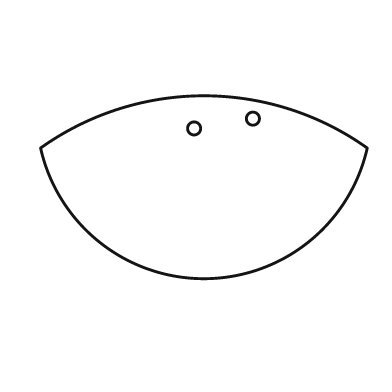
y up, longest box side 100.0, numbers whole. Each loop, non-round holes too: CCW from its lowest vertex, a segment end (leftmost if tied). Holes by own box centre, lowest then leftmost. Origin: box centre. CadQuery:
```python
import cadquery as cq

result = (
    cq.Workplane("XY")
    .moveTo(-50.0, 12.0)
    .threePointArc((0.0, -28.0), (50.0, 12.0))
    .threePointArc((0.0, 28.0), (-50.0, 12.0))
    .close()
    .moveTo(-3.0, 18.0)
    .circle(2.0)
    .moveTo(15.0, 21.0)
    .circle(2.0)
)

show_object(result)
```